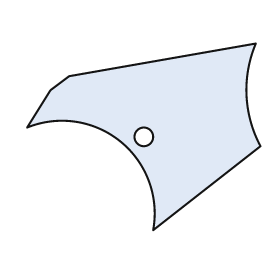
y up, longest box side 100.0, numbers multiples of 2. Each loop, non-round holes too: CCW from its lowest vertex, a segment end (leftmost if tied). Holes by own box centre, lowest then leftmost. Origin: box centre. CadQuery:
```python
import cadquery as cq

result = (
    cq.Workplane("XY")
    .moveTo(4.0, -40.0)
    .lineTo(50.0, -4.0)
    .threePointArc((44.0, 18.0), (48.0, 40.0))
    .lineTo(-32.0, 26.0)
    .lineTo(-40.0, 20.0)
    .lineTo(-50.0, 4.0)
    .threePointArc((-10.0, -2.0), (4.0, -40.0))
    .close()
    .moveTo(0.0, 0.0)
    .circle(4.0)
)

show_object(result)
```